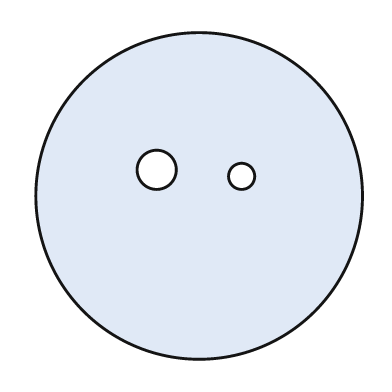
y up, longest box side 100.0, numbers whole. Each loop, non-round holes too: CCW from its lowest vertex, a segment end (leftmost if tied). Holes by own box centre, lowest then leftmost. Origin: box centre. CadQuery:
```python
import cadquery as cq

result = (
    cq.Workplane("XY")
    .moveTo(0.0, 0.0)
    .circle(50.0)
    .moveTo(13.0, 6.0)
    .circle(4.0)
    .moveTo(-13.0, 8.0)
    .circle(6.0)
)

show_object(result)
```